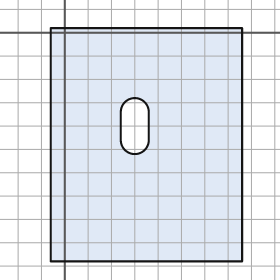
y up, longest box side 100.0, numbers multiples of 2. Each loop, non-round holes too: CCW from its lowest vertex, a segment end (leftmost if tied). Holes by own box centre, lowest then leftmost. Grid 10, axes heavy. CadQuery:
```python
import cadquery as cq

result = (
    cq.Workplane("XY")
    .moveTo(-6.0, -98.0)
    .lineTo(76.0, -98.0)
    .lineTo(76.0, 2.0)
    .lineTo(-6.0, 2.0)
    .close()
    .moveTo(24.0, -46.0)
    .threePointArc((30.0, -52.0), (36.0, -46.0))
    .lineTo(36.0, -34.0)
    .threePointArc((30.0, -28.0), (24.0, -34.0))
    .close()
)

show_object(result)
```